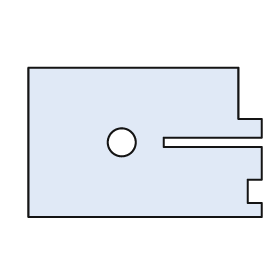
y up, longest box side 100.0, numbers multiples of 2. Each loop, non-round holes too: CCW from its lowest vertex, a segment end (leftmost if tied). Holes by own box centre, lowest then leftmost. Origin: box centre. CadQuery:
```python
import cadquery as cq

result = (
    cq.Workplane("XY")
    .moveTo(-50.0, -32.0)
    .lineTo(50.0, -32.0)
    .lineTo(50.0, -26.0)
    .lineTo(44.0, -26.0)
    .lineTo(44.0, -16.0)
    .lineTo(50.0, -16.0)
    .lineTo(50.0, -2.0)
    .lineTo(8.0, -2.0)
    .lineTo(8.0, 2.0)
    .lineTo(50.0, 2.0)
    .lineTo(50.0, 10.0)
    .lineTo(40.0, 10.0)
    .lineTo(40.0, 32.0)
    .lineTo(-50.0, 32.0)
    .close()
    .moveTo(-10.0, 0.0)
    .circle(6.0)
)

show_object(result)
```